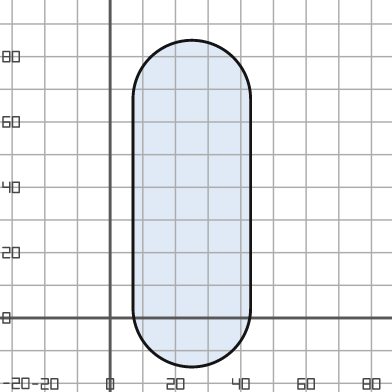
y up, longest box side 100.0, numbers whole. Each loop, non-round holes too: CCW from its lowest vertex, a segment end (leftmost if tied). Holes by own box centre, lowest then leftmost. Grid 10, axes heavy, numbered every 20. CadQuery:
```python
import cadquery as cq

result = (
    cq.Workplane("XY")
    .moveTo(7.0, 3.0)
    .threePointArc((25.0, -15.0), (43.0, 3.0))
    .lineTo(43.0, 67.0)
    .threePointArc((25.0, 85.0), (7.0, 67.0))
    .close()
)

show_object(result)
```